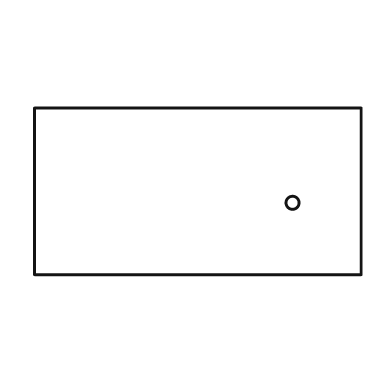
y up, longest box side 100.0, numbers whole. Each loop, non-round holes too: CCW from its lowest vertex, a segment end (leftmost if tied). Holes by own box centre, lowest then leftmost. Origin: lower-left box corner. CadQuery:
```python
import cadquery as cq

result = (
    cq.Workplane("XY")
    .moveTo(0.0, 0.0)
    .lineTo(100.0, 0.0)
    .lineTo(100.0, 51.0)
    .lineTo(0.0, 51.0)
    .close()
    .moveTo(79.0, 22.0)
    .circle(2.0)
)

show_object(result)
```